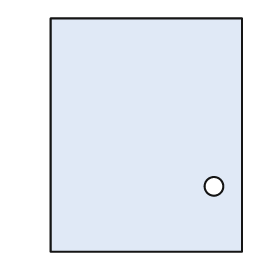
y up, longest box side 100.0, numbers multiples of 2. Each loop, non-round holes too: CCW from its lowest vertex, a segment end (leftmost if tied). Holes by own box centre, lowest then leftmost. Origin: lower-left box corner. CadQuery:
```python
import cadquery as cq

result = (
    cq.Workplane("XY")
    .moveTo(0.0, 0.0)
    .lineTo(82.0, 0.0)
    .lineTo(82.0, 100.0)
    .lineTo(0.0, 100.0)
    .close()
    .moveTo(70.0, 28.0)
    .circle(4.0)
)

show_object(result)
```